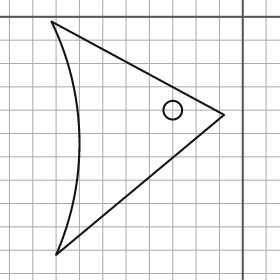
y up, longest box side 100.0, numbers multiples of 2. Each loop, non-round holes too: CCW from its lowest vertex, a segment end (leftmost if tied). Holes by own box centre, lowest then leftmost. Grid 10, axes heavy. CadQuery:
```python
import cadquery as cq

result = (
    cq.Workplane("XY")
    .moveTo(-80.0, -102.0)
    .lineTo(-8.0, -42.0)
    .lineTo(-82.0, -2.0)
    .threePointArc((-70.0, -52.0), (-80.0, -102.0))
    .close()
    .moveTo(-30.0, -40.0)
    .circle(4.0)
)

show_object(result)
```